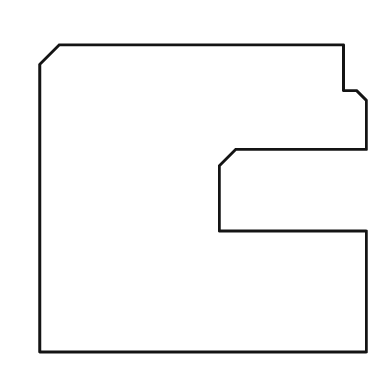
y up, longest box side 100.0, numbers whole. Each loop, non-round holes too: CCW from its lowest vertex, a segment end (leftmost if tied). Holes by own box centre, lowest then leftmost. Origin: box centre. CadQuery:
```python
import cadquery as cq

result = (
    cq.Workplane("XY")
    .moveTo(-50.0, -47.0)
    .lineTo(50.0, -47.0)
    .lineTo(50.0, -10.0)
    .lineTo(5.0, -10.0)
    .lineTo(5.0, 10.0)
    .lineTo(10.0, 15.0)
    .lineTo(50.0, 15.0)
    .lineTo(50.0, 30.0)
    .lineTo(47.0, 33.0)
    .lineTo(43.0, 33.0)
    .lineTo(43.0, 47.0)
    .lineTo(-44.0, 47.0)
    .lineTo(-50.0, 41.0)
    .close()
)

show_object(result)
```